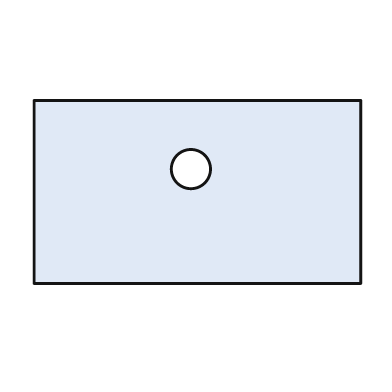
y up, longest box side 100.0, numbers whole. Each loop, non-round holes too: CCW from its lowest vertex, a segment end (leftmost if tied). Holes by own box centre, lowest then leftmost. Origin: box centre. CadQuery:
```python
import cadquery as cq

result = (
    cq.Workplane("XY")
    .moveTo(-50.0, -28.0)
    .lineTo(50.0, -28.0)
    .lineTo(50.0, 28.0)
    .lineTo(-50.0, 28.0)
    .close()
    .moveTo(-2.0, 7.0)
    .circle(6.0)
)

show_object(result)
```